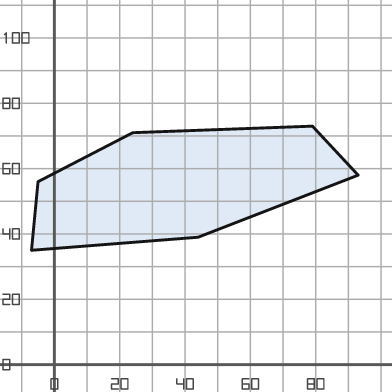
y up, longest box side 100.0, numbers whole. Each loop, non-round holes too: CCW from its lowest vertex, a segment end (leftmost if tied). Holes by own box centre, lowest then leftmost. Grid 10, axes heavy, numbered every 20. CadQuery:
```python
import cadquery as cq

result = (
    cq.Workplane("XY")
    .moveTo(-7.0, 35.0)
    .lineTo(44.0, 39.0)
    .lineTo(93.0, 58.0)
    .lineTo(79.0, 73.0)
    .lineTo(24.0, 71.0)
    .lineTo(-5.0, 56.0)
    .close()
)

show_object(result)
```